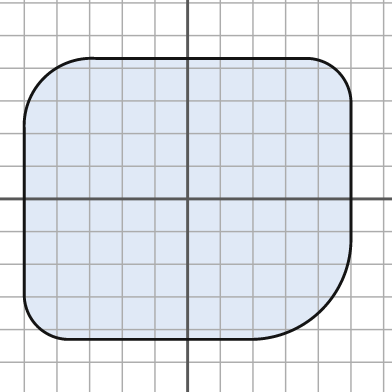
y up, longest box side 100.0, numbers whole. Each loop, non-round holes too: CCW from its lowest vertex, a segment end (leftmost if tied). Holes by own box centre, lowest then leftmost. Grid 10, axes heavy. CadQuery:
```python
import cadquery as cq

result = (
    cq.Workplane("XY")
    .moveTo(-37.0, -43.0)
    .lineTo(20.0, -43.0)
    .threePointArc((41.0, -34.0), (50.0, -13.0))
    .lineTo(50.0, 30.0)
    .threePointArc((46.0, 39.0), (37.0, 43.0))
    .lineTo(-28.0, 43.0)
    .threePointArc((-44.0, 37.0), (-50.0, 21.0))
    .lineTo(-50.0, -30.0)
    .threePointArc((-46.0, -39.0), (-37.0, -43.0))
    .close()
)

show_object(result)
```